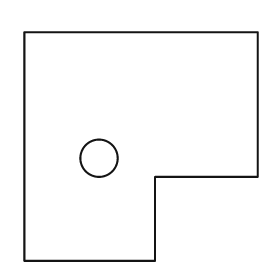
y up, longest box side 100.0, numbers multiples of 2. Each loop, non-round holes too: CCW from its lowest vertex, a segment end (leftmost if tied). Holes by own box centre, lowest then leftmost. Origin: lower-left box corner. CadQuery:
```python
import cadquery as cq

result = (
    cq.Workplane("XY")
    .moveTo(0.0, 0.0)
    .lineTo(56.0, 0.0)
    .lineTo(56.0, 36.0)
    .lineTo(100.0, 36.0)
    .lineTo(100.0, 98.0)
    .lineTo(0.0, 98.0)
    .close()
    .moveTo(32.0, 44.0)
    .circle(8.0)
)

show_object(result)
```